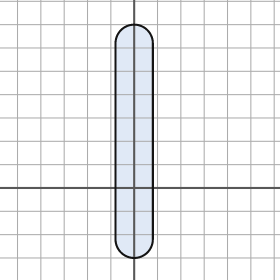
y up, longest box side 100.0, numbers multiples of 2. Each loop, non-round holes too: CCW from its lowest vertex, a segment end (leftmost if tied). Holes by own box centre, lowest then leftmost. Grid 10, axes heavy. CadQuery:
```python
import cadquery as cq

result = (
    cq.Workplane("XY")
    .moveTo(-8.0, -22.0)
    .threePointArc((0.0, -30.0), (8.0, -22.0))
    .lineTo(8.0, 62.0)
    .threePointArc((0.0, 70.0), (-8.0, 62.0))
    .close()
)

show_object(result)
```